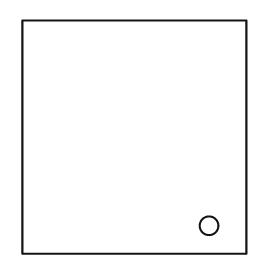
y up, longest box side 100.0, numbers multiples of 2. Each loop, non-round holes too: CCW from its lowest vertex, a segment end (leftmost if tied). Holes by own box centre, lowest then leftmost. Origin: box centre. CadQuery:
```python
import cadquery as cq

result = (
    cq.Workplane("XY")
    .moveTo(-48.0, -50.0)
    .lineTo(48.0, -50.0)
    .lineTo(48.0, 50.0)
    .lineTo(-48.0, 50.0)
    .close()
    .moveTo(32.0, -38.0)
    .circle(4.0)
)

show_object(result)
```